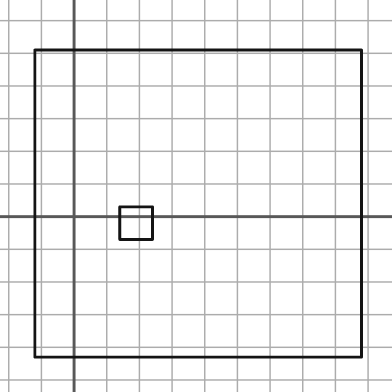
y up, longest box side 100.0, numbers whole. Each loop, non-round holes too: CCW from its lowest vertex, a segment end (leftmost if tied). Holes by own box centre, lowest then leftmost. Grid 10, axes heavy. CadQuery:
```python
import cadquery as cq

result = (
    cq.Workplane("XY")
    .moveTo(-12.0, -43.0)
    .lineTo(88.0, -43.0)
    .lineTo(88.0, 51.0)
    .lineTo(-12.0, 51.0)
    .close()
    .moveTo(14.0, -7.0)
    .lineTo(24.0, -7.0)
    .lineTo(24.0, 3.0)
    .lineTo(14.0, 3.0)
    .close()
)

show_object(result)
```